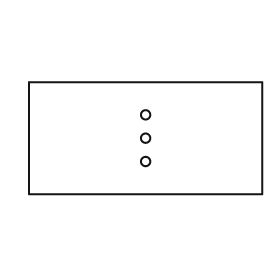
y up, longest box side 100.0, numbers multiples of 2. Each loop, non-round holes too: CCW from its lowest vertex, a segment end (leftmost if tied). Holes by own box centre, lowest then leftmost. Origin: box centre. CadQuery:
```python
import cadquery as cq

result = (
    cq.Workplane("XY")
    .moveTo(-50.0, -24.0)
    .lineTo(50.0, -24.0)
    .lineTo(50.0, 24.0)
    .lineTo(-50.0, 24.0)
    .close()
    .moveTo(0.0, -10.0)
    .circle(2.0)
    .moveTo(0.0, 0.0)
    .circle(2.0)
    .moveTo(0.0, 10.0)
    .circle(2.0)
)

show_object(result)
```